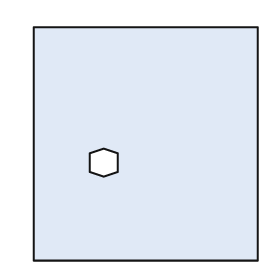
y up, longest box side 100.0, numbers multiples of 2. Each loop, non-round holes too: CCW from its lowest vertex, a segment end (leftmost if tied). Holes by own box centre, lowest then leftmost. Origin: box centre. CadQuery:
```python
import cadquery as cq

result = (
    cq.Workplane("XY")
    .moveTo(-48.0, -50.0)
    .lineTo(48.0, -50.0)
    .lineTo(48.0, 50.0)
    .lineTo(-48.0, 50.0)
    .close()
    .moveTo(-18.0, -14.0)
    .lineTo(-12.0, -12.0)
    .lineTo(-12.0, -4.0)
    .lineTo(-18.0, -2.0)
    .lineTo(-24.0, -4.0)
    .lineTo(-24.0, -12.0)
    .close()
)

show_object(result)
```